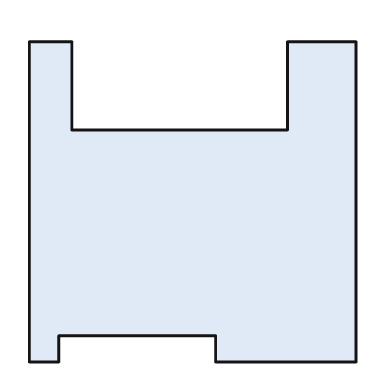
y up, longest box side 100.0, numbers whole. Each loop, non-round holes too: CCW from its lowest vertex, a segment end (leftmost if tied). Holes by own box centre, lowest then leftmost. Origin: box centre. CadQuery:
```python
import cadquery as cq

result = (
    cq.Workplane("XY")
    .moveTo(-50.0, -49.0)
    .lineTo(-41.0, -49.0)
    .lineTo(-41.0, -41.0)
    .lineTo(7.0, -41.0)
    .lineTo(7.0, -49.0)
    .lineTo(50.0, -49.0)
    .lineTo(50.0, 49.0)
    .lineTo(29.0, 49.0)
    .lineTo(29.0, 22.0)
    .lineTo(-37.0, 22.0)
    .lineTo(-37.0, 49.0)
    .lineTo(-50.0, 49.0)
    .close()
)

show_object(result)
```